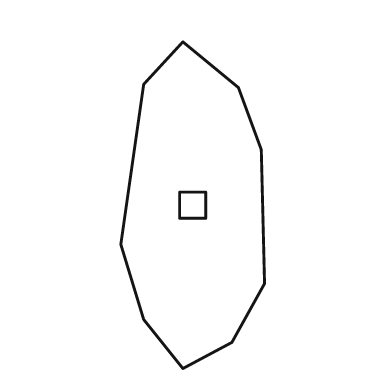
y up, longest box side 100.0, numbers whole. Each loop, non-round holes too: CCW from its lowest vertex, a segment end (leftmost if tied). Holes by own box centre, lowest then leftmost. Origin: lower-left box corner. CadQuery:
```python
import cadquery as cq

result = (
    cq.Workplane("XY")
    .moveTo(19.0, 0.0)
    .lineTo(34.0, 8.0)
    .lineTo(44.0, 26.0)
    .lineTo(43.0, 67.0)
    .lineTo(36.0, 86.0)
    .lineTo(19.0, 100.0)
    .lineTo(7.0, 87.0)
    .lineTo(0.0, 38.0)
    .lineTo(7.0, 15.0)
    .close()
    .moveTo(18.0, 46.0)
    .lineTo(26.0, 46.0)
    .lineTo(26.0, 54.0)
    .lineTo(18.0, 54.0)
    .close()
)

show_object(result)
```